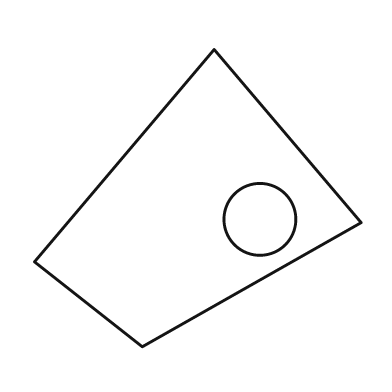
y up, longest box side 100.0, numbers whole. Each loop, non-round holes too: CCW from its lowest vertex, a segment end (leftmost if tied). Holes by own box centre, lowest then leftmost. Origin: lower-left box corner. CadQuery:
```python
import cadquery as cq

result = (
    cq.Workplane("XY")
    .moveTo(33.0, 0.0)
    .lineTo(100.0, 38.0)
    .lineTo(55.0, 91.0)
    .lineTo(0.0, 26.0)
    .close()
    .moveTo(69.0, 39.0)
    .circle(11.0)
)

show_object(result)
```